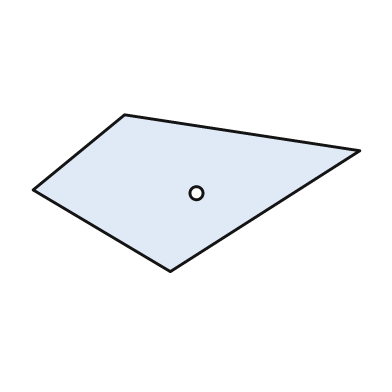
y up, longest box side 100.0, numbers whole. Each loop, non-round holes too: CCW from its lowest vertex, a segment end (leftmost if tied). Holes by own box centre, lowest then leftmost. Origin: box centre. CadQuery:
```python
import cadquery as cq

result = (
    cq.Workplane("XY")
    .moveTo(-8.0, -24.0)
    .lineTo(50.0, 13.0)
    .lineTo(-22.0, 24.0)
    .lineTo(-50.0, 1.0)
    .close()
    .moveTo(0.0, 0.0)
    .circle(2.0)
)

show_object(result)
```